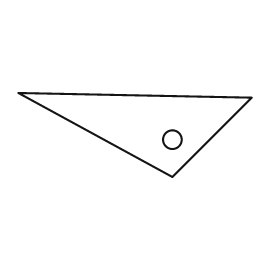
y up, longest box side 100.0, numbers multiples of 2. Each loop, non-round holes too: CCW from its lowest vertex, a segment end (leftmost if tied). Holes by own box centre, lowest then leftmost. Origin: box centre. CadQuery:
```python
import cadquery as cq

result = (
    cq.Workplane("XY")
    .moveTo(16.0, -18.0)
    .lineTo(50.0, 16.0)
    .lineTo(-50.0, 18.0)
    .close()
    .moveTo(16.0, -2.0)
    .circle(4.0)
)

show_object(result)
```